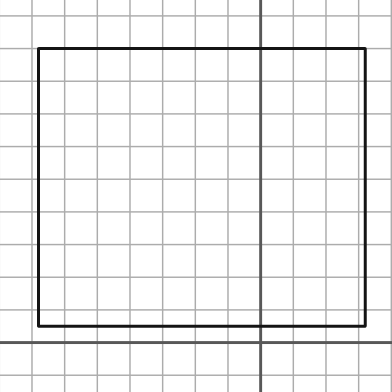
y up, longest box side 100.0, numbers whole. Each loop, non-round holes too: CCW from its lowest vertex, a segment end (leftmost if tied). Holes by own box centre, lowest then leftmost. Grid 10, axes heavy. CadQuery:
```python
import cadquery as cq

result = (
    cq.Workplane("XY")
    .moveTo(-68.0, 5.0)
    .lineTo(32.0, 5.0)
    .lineTo(32.0, 90.0)
    .lineTo(-68.0, 90.0)
    .close()
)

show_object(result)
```